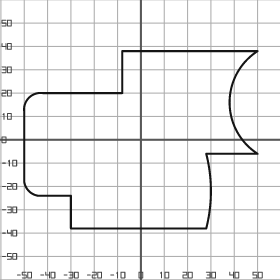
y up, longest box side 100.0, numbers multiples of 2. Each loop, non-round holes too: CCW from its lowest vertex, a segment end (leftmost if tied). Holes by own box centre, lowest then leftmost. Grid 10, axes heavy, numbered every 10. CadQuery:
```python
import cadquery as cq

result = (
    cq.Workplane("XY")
    .moveTo(-30.0, -38.0)
    .lineTo(28.0, -38.0)
    .threePointArc((30.0, -22.0), (28.0, -6.0))
    .lineTo(50.0, -6.0)
    .threePointArc((38.0, 16.0), (50.0, 38.0))
    .lineTo(-8.0, 38.0)
    .lineTo(-8.0, 20.0)
    .lineTo(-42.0, 20.0)
    .threePointArc((-48.0, 18.0), (-50.0, 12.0))
    .lineTo(-50.0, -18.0)
    .threePointArc((-48.0, -22.0), (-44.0, -24.0))
    .lineTo(-30.0, -24.0)
    .close()
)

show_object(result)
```